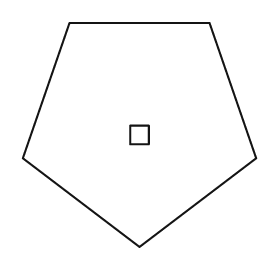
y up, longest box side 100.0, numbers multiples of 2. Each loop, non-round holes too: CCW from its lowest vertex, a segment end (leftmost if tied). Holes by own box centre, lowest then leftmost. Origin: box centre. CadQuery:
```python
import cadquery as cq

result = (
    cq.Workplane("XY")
    .moveTo(0.0, -48.0)
    .lineTo(50.0, -10.0)
    .lineTo(30.0, 48.0)
    .lineTo(-30.0, 48.0)
    .lineTo(-50.0, -10.0)
    .close()
    .moveTo(-4.0, -4.0)
    .lineTo(4.0, -4.0)
    .lineTo(4.0, 4.0)
    .lineTo(-4.0, 4.0)
    .close()
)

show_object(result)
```